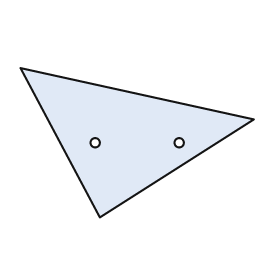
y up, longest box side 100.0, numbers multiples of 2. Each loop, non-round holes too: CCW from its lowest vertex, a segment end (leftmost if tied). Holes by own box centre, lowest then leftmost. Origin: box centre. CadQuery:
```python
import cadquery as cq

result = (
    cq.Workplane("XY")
    .moveTo(-16.0, -32.0)
    .lineTo(50.0, 10.0)
    .lineTo(-50.0, 32.0)
    .close()
    .moveTo(-18.0, 0.0)
    .circle(2.0)
    .moveTo(18.0, 0.0)
    .circle(2.0)
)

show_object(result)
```